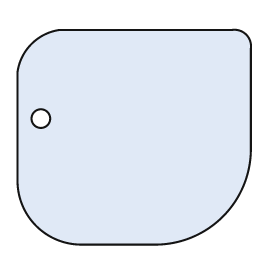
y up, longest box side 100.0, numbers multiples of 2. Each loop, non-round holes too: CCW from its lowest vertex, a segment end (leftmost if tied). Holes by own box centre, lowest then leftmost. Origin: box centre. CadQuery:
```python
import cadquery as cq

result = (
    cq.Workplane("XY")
    .moveTo(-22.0, -46.0)
    .lineTo(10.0, -46.0)
    .threePointArc((38.0, -34.0), (50.0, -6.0))
    .lineTo(50.0, 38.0)
    .threePointArc((48.0, 44.0), (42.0, 46.0))
    .lineTo(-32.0, 46.0)
    .threePointArc((-44.0, 40.0), (-50.0, 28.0))
    .lineTo(-50.0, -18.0)
    .threePointArc((-42.0, -38.0), (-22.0, -46.0))
    .close()
    .moveTo(-40.0, 8.0)
    .circle(4.0)
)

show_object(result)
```